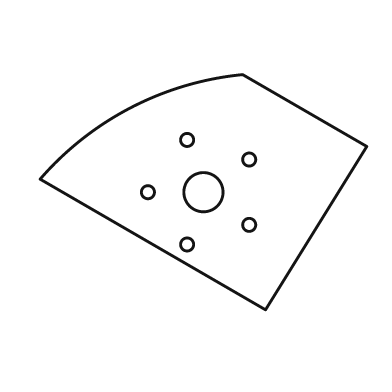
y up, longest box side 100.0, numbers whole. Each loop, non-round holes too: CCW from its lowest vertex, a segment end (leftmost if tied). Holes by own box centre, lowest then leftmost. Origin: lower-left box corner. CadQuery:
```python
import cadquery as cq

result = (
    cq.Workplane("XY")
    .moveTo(69.0, 0.0)
    .lineTo(100.0, 50.0)
    .lineTo(62.0, 72.0)
    .threePointArc((28.0, 62.0), (0.0, 40.0))
    .close()
    .moveTo(45.0, 20.0)
    .circle(2.0)
    .moveTo(64.0, 26.0)
    .circle(2.0)
    .moveTo(33.0, 36.0)
    .circle(2.0)
    .moveTo(50.0, 36.0)
    .circle(6.0)
    .moveTo(64.0, 46.0)
    .circle(2.0)
    .moveTo(45.0, 52.0)
    .circle(2.0)
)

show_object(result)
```